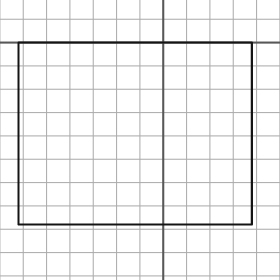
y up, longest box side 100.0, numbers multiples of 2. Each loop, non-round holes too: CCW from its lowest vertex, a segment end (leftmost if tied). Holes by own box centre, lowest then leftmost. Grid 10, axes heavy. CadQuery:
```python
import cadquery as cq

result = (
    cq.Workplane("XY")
    .moveTo(-62.0, -78.0)
    .lineTo(38.0, -78.0)
    .lineTo(38.0, 0.0)
    .lineTo(-62.0, 0.0)
    .close()
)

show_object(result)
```